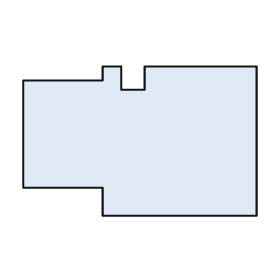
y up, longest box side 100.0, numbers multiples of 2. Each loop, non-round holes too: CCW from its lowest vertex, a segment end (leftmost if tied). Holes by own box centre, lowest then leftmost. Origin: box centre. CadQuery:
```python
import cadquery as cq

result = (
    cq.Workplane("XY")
    .moveTo(-16.0, -32.0)
    .lineTo(50.0, -32.0)
    .lineTo(50.0, 32.0)
    .lineTo(2.0, 32.0)
    .lineTo(2.0, 22.0)
    .lineTo(-8.0, 22.0)
    .lineTo(-8.0, 32.0)
    .lineTo(-16.0, 32.0)
    .lineTo(-16.0, 26.0)
    .lineTo(-50.0, 26.0)
    .lineTo(-50.0, -20.0)
    .lineTo(-16.0, -20.0)
    .close()
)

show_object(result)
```